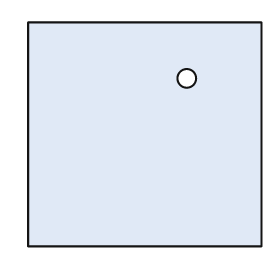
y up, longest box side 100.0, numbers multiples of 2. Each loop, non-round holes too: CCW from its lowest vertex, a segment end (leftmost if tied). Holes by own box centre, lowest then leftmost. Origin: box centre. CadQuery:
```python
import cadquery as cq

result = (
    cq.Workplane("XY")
    .moveTo(-50.0, -48.0)
    .lineTo(50.0, -48.0)
    .lineTo(50.0, 48.0)
    .lineTo(-50.0, 48.0)
    .close()
    .moveTo(18.0, 24.0)
    .circle(4.0)
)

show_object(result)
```